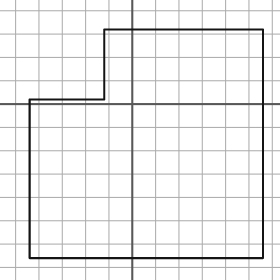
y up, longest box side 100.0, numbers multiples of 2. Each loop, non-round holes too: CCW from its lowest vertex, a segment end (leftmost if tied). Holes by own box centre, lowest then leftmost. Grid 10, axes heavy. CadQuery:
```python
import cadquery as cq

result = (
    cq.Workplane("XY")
    .moveTo(-44.0, -66.0)
    .lineTo(56.0, -66.0)
    .lineTo(56.0, 32.0)
    .lineTo(-12.0, 32.0)
    .lineTo(-12.0, 2.0)
    .lineTo(-44.0, 2.0)
    .close()
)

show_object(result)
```